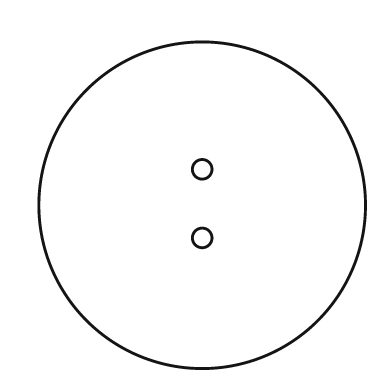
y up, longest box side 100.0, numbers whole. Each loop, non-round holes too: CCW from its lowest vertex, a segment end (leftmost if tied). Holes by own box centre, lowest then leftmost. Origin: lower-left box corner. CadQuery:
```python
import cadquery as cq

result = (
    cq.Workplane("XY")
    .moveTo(50.0, 50.0)
    .circle(50.0)
    .moveTo(50.0, 40.0)
    .circle(3.0)
    .moveTo(50.0, 61.0)
    .circle(3.0)
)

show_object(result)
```